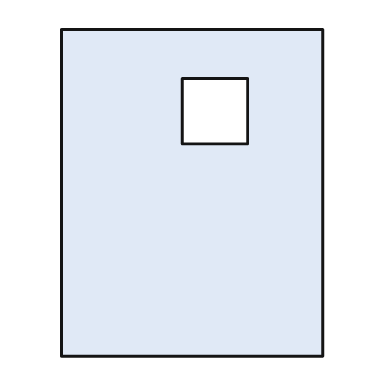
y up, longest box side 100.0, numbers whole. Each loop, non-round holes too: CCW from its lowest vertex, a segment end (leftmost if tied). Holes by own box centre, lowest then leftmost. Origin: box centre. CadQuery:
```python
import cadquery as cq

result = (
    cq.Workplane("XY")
    .moveTo(-40.0, -50.0)
    .lineTo(40.0, -50.0)
    .lineTo(40.0, 50.0)
    .lineTo(-40.0, 50.0)
    .close()
    .moveTo(-3.0, 15.0)
    .lineTo(17.0, 15.0)
    .lineTo(17.0, 35.0)
    .lineTo(-3.0, 35.0)
    .close()
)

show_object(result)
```